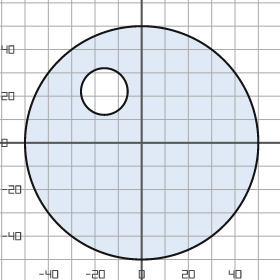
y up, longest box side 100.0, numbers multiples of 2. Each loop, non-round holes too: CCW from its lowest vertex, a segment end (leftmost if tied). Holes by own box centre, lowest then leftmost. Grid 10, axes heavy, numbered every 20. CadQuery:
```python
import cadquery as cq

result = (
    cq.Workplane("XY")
    .moveTo(0.0, 0.0)
    .circle(50.0)
    .moveTo(-16.0, 22.0)
    .circle(10.0)
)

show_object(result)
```